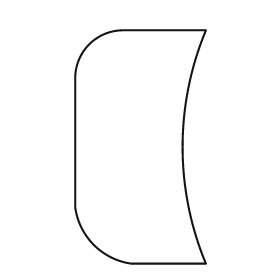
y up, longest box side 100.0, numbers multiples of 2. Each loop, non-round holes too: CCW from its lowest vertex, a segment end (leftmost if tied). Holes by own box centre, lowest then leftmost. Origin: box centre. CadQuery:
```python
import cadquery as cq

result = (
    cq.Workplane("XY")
    .moveTo(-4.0, -50.0)
    .lineTo(28.0, -50.0)
    .threePointArc((18.0, 0.0), (28.0, 50.0))
    .lineTo(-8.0, 50.0)
    .threePointArc((-22.0, 44.0), (-28.0, 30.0))
    .lineTo(-28.0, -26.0)
    .threePointArc((-20.0, -42.0), (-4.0, -50.0))
    .close()
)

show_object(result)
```